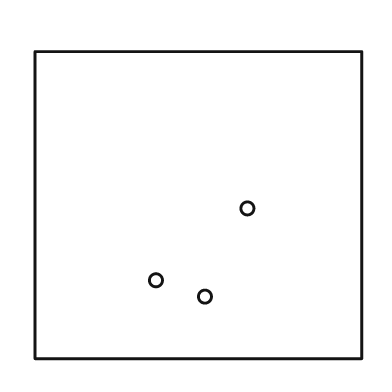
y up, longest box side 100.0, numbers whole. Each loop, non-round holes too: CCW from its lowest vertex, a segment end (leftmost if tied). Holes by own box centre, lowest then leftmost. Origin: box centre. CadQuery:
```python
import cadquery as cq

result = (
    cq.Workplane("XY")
    .moveTo(-50.0, -47.0)
    .lineTo(50.0, -47.0)
    .lineTo(50.0, 47.0)
    .lineTo(-50.0, 47.0)
    .close()
    .moveTo(2.0, -28.0)
    .circle(2.0)
    .moveTo(-13.0, -23.0)
    .circle(2.0)
    .moveTo(15.0, -1.0)
    .circle(2.0)
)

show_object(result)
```